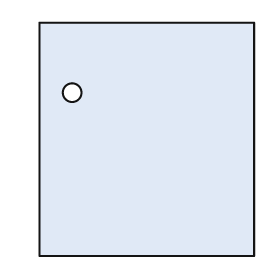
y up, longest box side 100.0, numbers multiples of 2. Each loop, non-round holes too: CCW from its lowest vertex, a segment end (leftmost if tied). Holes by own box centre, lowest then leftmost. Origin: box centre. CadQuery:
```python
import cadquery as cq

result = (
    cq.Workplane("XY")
    .moveTo(-46.0, -50.0)
    .lineTo(46.0, -50.0)
    .lineTo(46.0, 50.0)
    .lineTo(-46.0, 50.0)
    .close()
    .moveTo(-32.0, 20.0)
    .circle(4.0)
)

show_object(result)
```